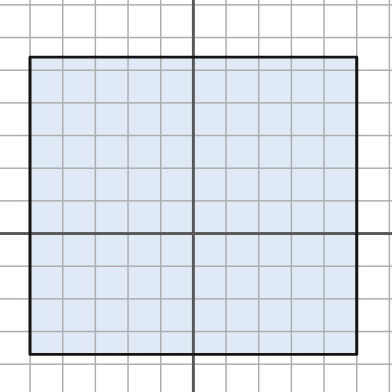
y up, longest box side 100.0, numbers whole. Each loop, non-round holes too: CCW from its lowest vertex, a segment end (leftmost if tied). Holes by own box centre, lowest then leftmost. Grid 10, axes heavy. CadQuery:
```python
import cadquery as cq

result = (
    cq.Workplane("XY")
    .moveTo(-50.0, -37.0)
    .lineTo(50.0, -37.0)
    .lineTo(50.0, 54.0)
    .lineTo(-50.0, 54.0)
    .close()
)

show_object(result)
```